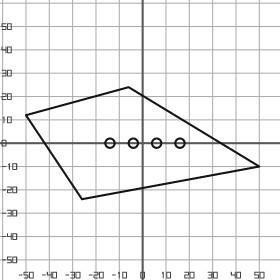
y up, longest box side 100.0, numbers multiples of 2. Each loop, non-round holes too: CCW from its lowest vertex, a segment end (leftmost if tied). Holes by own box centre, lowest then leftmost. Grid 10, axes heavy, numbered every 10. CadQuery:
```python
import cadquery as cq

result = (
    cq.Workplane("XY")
    .moveTo(-26.0, -24.0)
    .lineTo(50.0, -10.0)
    .lineTo(-6.0, 24.0)
    .lineTo(-50.0, 12.0)
    .close()
    .moveTo(-14.0, 0.0)
    .circle(2.0)
    .moveTo(-4.0, 0.0)
    .circle(2.0)
    .moveTo(6.0, 0.0)
    .circle(2.0)
    .moveTo(16.0, 0.0)
    .circle(2.0)
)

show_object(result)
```